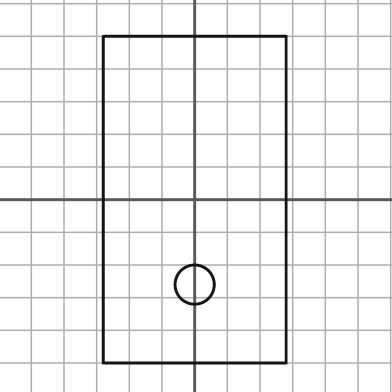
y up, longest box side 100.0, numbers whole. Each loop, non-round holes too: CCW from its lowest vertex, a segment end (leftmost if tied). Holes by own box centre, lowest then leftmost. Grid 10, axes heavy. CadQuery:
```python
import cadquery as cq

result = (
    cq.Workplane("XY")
    .moveTo(-28.0, -50.0)
    .lineTo(28.0, -50.0)
    .lineTo(28.0, 50.0)
    .lineTo(-28.0, 50.0)
    .close()
    .moveTo(0.0, -26.0)
    .circle(6.0)
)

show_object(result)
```